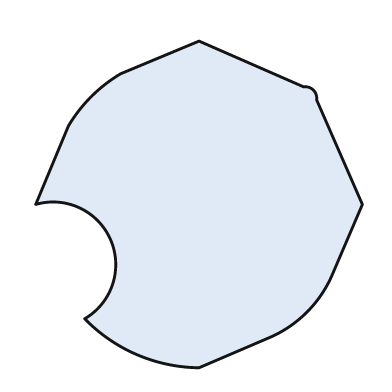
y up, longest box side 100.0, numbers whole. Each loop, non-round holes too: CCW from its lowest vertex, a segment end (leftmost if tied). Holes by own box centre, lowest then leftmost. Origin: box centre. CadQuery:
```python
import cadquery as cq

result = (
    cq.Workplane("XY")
    .moveTo(0.0, -50.0)
    .lineTo(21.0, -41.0)
    .threePointArc((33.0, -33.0), (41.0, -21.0))
    .lineTo(50.0, 0.0)
    .lineTo(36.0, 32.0)
    .threePointArc((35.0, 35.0), (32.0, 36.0))
    .lineTo(0.0, 50.0)
    .lineTo(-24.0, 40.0)
    .threePointArc((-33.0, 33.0), (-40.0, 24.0))
    .lineTo(-50.0, 0.0)
    .threePointArc((-27.0, -11.0), (-35.0, -35.0))
    .threePointArc((-19.0, -46.0), (0.0, -50.0))
    .close()
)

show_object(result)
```